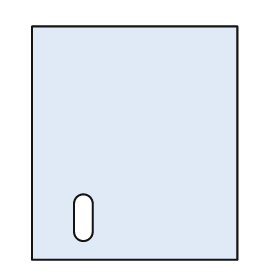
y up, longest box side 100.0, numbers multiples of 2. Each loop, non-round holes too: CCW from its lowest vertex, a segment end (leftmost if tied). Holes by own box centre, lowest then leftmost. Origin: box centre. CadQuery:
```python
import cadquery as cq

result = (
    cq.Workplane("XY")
    .moveTo(-44.0, -50.0)
    .lineTo(44.0, -50.0)
    .lineTo(44.0, 50.0)
    .lineTo(-44.0, 50.0)
    .close()
    .moveTo(-26.0, -38.0)
    .threePointArc((-22.0, -42.0), (-18.0, -38.0))
    .lineTo(-18.0, -26.0)
    .threePointArc((-22.0, -22.0), (-26.0, -26.0))
    .close()
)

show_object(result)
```